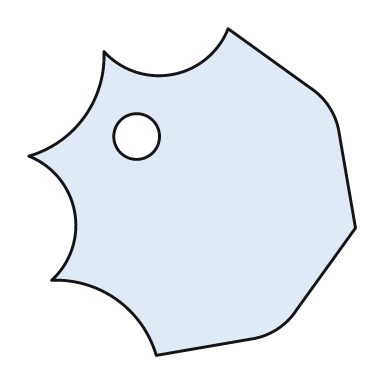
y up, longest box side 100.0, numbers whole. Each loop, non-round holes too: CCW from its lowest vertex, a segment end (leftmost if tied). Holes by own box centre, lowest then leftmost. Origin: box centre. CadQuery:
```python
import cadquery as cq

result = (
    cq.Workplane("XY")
    .moveTo(-11.0, -50.0)
    .lineTo(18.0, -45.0)
    .threePointArc((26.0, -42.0), (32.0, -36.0))
    .lineTo(50.0, -11.0)
    .lineTo(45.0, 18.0)
    .threePointArc((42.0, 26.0), (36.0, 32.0))
    .lineTo(11.0, 50.0)
    .threePointArc((-6.0, 36.0), (-27.0, 43.0))
    .threePointArc((-33.0, 23.0), (-50.0, 11.0))
    .threePointArc((-36.0, -6.0), (-43.0, -27.0))
    .threePointArc((-23.0, -33.0), (-11.0, -50.0))
    .close()
    .moveTo(-17.0, 17.0)
    .circle(7.0)
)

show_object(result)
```